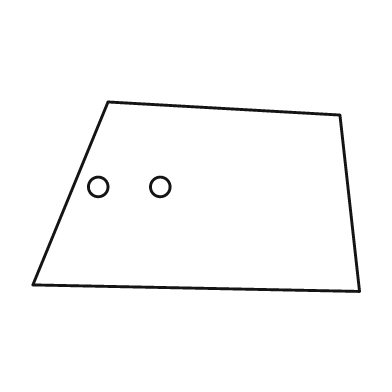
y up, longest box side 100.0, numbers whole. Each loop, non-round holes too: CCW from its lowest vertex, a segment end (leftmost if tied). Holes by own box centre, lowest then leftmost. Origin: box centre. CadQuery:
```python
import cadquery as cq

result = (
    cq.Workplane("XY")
    .moveTo(50.0, -29.0)
    .lineTo(44.0, 25.0)
    .lineTo(-27.0, 29.0)
    .lineTo(-50.0, -27.0)
    .close()
    .moveTo(-30.0, 3.0)
    .circle(3.0)
    .moveTo(-11.0, 3.0)
    .circle(3.0)
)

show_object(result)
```